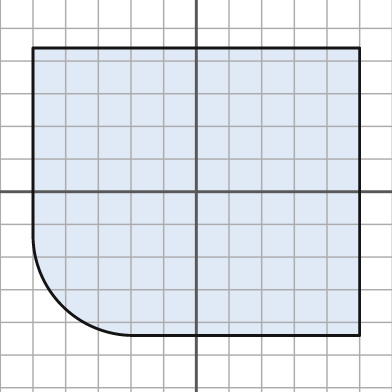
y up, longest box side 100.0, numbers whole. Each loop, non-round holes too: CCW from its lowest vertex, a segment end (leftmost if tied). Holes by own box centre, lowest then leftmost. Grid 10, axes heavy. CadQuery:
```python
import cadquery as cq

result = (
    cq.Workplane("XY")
    .moveTo(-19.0, -44.0)
    .lineTo(50.0, -44.0)
    .lineTo(50.0, 44.0)
    .lineTo(-50.0, 44.0)
    .lineTo(-50.0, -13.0)
    .threePointArc((-41.0, -35.0), (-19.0, -44.0))
    .close()
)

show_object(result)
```